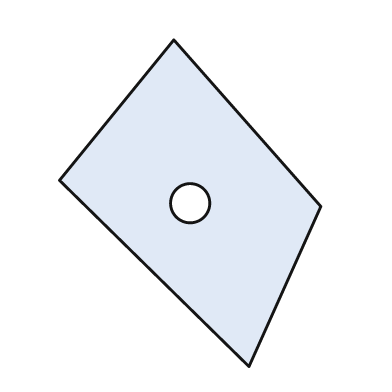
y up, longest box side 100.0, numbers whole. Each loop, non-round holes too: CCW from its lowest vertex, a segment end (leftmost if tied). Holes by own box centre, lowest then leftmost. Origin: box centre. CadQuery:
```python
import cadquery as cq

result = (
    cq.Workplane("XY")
    .moveTo(18.0, -50.0)
    .lineTo(40.0, -1.0)
    .lineTo(-5.0, 50.0)
    .lineTo(-40.0, 7.0)
    .close()
    .moveTo(0.0, 0.0)
    .circle(6.0)
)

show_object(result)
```